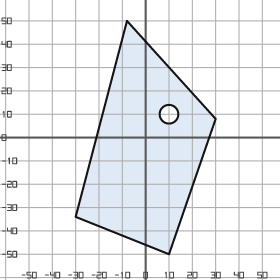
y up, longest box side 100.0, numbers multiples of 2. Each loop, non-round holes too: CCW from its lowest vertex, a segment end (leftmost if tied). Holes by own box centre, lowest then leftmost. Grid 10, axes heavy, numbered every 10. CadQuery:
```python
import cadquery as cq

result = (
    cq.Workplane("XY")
    .moveTo(10.0, -50.0)
    .lineTo(30.0, 8.0)
    .lineTo(-8.0, 50.0)
    .lineTo(-30.0, -34.0)
    .close()
    .moveTo(10.0, 10.0)
    .circle(4.0)
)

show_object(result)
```